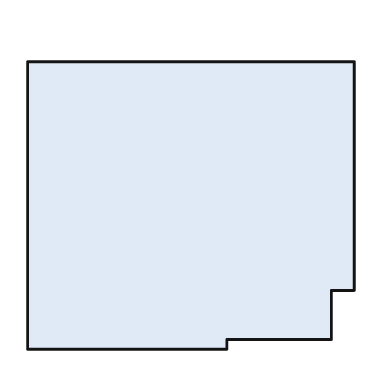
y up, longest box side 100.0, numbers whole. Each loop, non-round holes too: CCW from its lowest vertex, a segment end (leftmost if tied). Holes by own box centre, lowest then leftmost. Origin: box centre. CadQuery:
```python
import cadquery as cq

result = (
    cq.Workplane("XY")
    .moveTo(-50.0, -44.0)
    .lineTo(11.0, -44.0)
    .lineTo(11.0, -41.0)
    .lineTo(43.0, -41.0)
    .lineTo(43.0, -26.0)
    .lineTo(50.0, -26.0)
    .lineTo(50.0, 44.0)
    .lineTo(-50.0, 44.0)
    .close()
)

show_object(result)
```